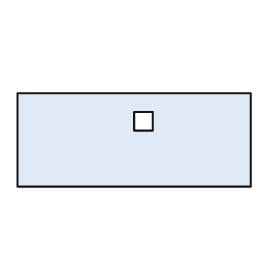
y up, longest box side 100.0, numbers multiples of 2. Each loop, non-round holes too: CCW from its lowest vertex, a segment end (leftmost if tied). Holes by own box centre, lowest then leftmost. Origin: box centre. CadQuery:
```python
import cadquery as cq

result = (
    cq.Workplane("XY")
    .moveTo(-50.0, -20.0)
    .lineTo(50.0, -20.0)
    .lineTo(50.0, 20.0)
    .lineTo(-50.0, 20.0)
    .close()
    .moveTo(0.0, 4.0)
    .lineTo(8.0, 4.0)
    .lineTo(8.0, 12.0)
    .lineTo(0.0, 12.0)
    .close()
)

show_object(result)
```